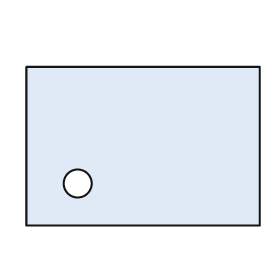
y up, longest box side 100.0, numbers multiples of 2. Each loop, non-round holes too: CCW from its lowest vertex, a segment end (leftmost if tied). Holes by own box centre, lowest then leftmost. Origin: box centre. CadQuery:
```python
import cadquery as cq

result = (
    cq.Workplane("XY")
    .moveTo(-50.0, -34.0)
    .lineTo(50.0, -34.0)
    .lineTo(50.0, 34.0)
    .lineTo(-50.0, 34.0)
    .close()
    .moveTo(-28.0, -16.0)
    .circle(6.0)
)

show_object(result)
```